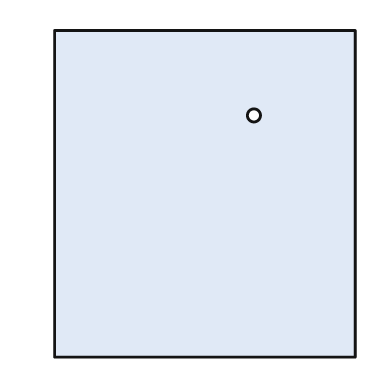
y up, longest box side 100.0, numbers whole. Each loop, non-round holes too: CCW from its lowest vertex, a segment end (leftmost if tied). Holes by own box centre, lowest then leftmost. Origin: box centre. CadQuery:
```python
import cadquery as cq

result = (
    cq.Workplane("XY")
    .moveTo(-46.0, -50.0)
    .lineTo(46.0, -50.0)
    .lineTo(46.0, 50.0)
    .lineTo(-46.0, 50.0)
    .close()
    .moveTo(15.0, 24.0)
    .circle(2.0)
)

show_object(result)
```